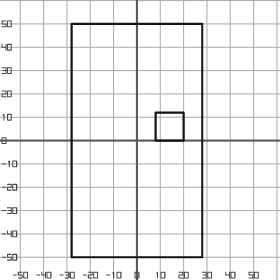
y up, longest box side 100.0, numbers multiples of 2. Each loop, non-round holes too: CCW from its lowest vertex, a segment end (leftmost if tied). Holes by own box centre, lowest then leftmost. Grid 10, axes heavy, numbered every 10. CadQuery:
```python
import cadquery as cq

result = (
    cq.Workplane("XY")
    .moveTo(-28.0, -50.0)
    .lineTo(28.0, -50.0)
    .lineTo(28.0, 50.0)
    .lineTo(-28.0, 50.0)
    .close()
    .moveTo(8.0, 0.0)
    .lineTo(20.0, 0.0)
    .lineTo(20.0, 12.0)
    .lineTo(8.0, 12.0)
    .close()
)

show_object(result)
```